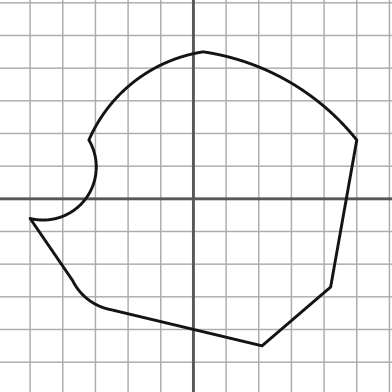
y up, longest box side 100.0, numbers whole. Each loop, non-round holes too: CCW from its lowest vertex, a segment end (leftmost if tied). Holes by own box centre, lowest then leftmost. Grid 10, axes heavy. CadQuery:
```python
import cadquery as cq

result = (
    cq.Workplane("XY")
    .moveTo(21.0, -45.0)
    .lineTo(42.0, -27.0)
    .lineTo(50.0, 18.0)
    .threePointArc((29.0, 36.0), (3.0, 45.0))
    .threePointArc((-18.0, 36.0), (-32.0, 18.0))
    .threePointArc((-33.0, 0.0), (-50.0, -6.0))
    .lineTo(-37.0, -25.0)
    .threePointArc((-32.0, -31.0), (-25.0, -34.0))
    .close()
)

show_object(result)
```